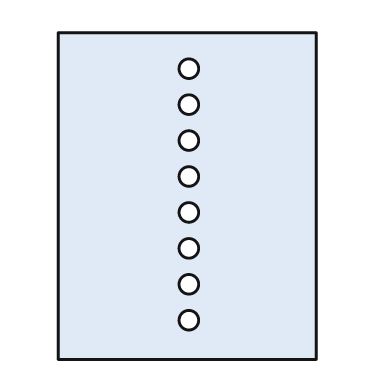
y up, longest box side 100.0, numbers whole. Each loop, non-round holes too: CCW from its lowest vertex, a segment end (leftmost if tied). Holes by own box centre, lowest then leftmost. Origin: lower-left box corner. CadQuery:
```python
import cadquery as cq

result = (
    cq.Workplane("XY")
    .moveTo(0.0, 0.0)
    .lineTo(79.0, 0.0)
    .lineTo(79.0, 100.0)
    .lineTo(0.0, 100.0)
    .close()
    .moveTo(40.0, 12.0)
    .circle(3.0)
    .moveTo(40.0, 23.0)
    .circle(3.0)
    .moveTo(40.0, 34.0)
    .circle(3.0)
    .moveTo(40.0, 45.0)
    .circle(3.0)
    .moveTo(40.0, 56.0)
    .circle(3.0)
    .moveTo(40.0, 67.0)
    .circle(3.0)
    .moveTo(40.0, 78.0)
    .circle(3.0)
    .moveTo(40.0, 89.0)
    .circle(3.0)
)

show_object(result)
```